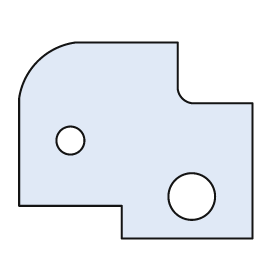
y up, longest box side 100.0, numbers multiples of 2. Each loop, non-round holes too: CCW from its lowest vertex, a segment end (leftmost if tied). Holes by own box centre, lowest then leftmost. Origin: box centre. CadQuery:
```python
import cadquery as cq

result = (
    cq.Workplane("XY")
    .moveTo(-6.0, -42.0)
    .lineTo(50.0, -42.0)
    .lineTo(50.0, 16.0)
    .lineTo(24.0, 16.0)
    .threePointArc((20.0, 18.0), (18.0, 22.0))
    .lineTo(18.0, 42.0)
    .lineTo(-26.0, 42.0)
    .threePointArc((-42.0, 34.0), (-50.0, 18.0))
    .lineTo(-50.0, -28.0)
    .lineTo(-6.0, -28.0)
    .close()
    .moveTo(24.0, -24.0)
    .circle(10.0)
    .moveTo(-28.0, 0.0)
    .circle(6.0)
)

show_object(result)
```